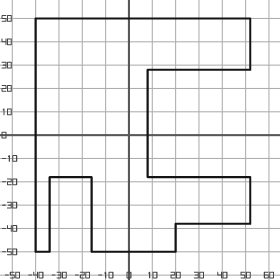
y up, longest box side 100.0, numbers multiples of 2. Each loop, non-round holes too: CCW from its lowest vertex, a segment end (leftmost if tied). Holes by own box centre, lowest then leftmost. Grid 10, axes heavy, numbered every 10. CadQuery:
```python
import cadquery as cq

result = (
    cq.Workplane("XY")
    .moveTo(-40.0, -50.0)
    .lineTo(-34.0, -50.0)
    .lineTo(-34.0, -18.0)
    .lineTo(-16.0, -18.0)
    .lineTo(-16.0, -50.0)
    .lineTo(20.0, -50.0)
    .lineTo(20.0, -38.0)
    .lineTo(52.0, -38.0)
    .lineTo(52.0, -18.0)
    .lineTo(8.0, -18.0)
    .lineTo(8.0, 28.0)
    .lineTo(52.0, 28.0)
    .lineTo(52.0, 50.0)
    .lineTo(-40.0, 50.0)
    .close()
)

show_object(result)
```